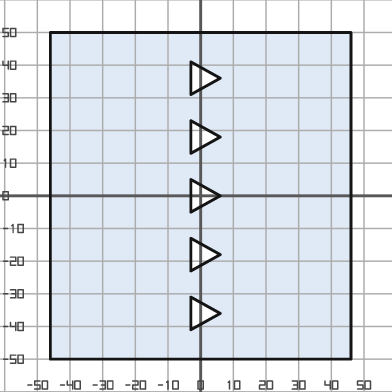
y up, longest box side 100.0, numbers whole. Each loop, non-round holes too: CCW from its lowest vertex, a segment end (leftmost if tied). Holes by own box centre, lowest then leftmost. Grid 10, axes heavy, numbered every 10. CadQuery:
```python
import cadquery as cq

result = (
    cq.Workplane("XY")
    .moveTo(-46.0, -50.0)
    .lineTo(46.0, -50.0)
    .lineTo(46.0, 50.0)
    .lineTo(-46.0, 50.0)
    .close()
    .moveTo(-3.0, -41.0)
    .lineTo(6.0, -36.0)
    .lineTo(-3.0, -31.0)
    .close()
    .moveTo(-3.0, -23.0)
    .lineTo(6.0, -18.0)
    .lineTo(-3.0, -13.0)
    .close()
    .moveTo(-3.0, -5.0)
    .lineTo(6.0, 0.0)
    .lineTo(-3.0, 5.0)
    .close()
    .moveTo(-3.0, 13.0)
    .lineTo(6.0, 18.0)
    .lineTo(-3.0, 23.0)
    .close()
    .moveTo(-3.0, 31.0)
    .lineTo(6.0, 36.0)
    .lineTo(-3.0, 41.0)
    .close()
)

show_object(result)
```